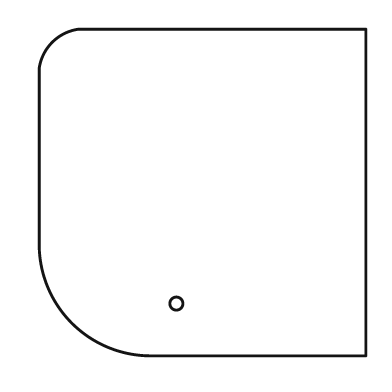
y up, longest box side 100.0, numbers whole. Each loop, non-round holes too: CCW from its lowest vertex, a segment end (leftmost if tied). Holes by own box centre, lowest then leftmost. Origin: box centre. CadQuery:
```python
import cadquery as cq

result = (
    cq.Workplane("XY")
    .moveTo(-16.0, -50.0)
    .lineTo(50.0, -50.0)
    .lineTo(50.0, 50.0)
    .lineTo(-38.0, 50.0)
    .threePointArc((-46.0, 46.0), (-50.0, 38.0))
    .lineTo(-50.0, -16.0)
    .threePointArc((-40.0, -40.0), (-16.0, -50.0))
    .close()
    .moveTo(-8.0, -34.0)
    .circle(2.0)
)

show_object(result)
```